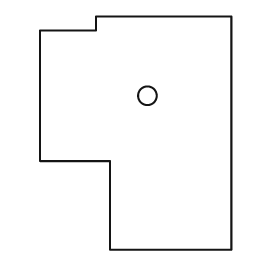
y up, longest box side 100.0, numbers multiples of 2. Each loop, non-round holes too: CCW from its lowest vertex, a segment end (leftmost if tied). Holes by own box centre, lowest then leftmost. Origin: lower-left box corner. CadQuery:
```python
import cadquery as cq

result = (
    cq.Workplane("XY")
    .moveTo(30.0, 0.0)
    .lineTo(82.0, 0.0)
    .lineTo(82.0, 100.0)
    .lineTo(24.0, 100.0)
    .lineTo(24.0, 94.0)
    .lineTo(0.0, 94.0)
    .lineTo(0.0, 38.0)
    .lineTo(30.0, 38.0)
    .close()
    .moveTo(46.0, 66.0)
    .circle(4.0)
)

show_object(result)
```